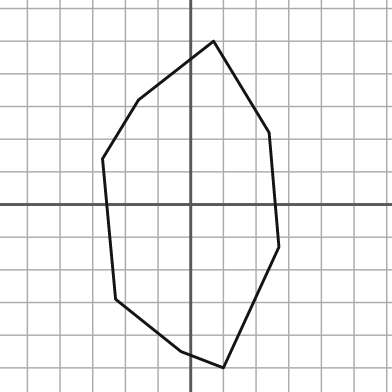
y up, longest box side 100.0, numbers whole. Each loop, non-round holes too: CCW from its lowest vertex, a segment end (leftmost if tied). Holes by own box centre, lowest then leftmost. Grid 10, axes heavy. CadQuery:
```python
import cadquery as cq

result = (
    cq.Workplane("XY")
    .moveTo(10.0, -50.0)
    .lineTo(27.0, -13.0)
    .lineTo(24.0, 22.0)
    .lineTo(7.0, 50.0)
    .lineTo(-16.0, 32.0)
    .lineTo(-27.0, 14.0)
    .lineTo(-23.0, -29.0)
    .lineTo(-3.0, -45.0)
    .close()
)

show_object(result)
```